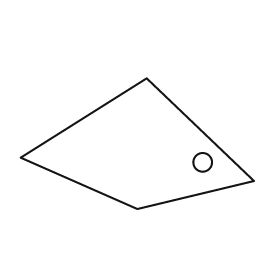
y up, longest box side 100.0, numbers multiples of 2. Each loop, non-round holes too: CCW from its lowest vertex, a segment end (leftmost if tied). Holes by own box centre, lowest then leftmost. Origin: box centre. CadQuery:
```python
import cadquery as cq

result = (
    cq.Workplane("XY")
    .moveTo(0.0, -28.0)
    .lineTo(50.0, -16.0)
    .lineTo(4.0, 28.0)
    .lineTo(-50.0, -6.0)
    .close()
    .moveTo(28.0, -8.0)
    .circle(4.0)
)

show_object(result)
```